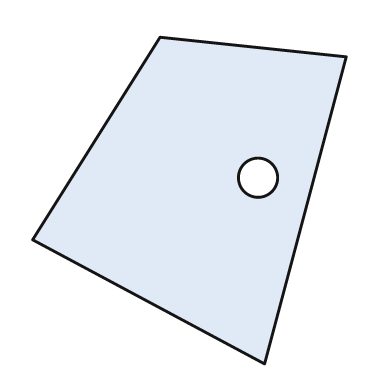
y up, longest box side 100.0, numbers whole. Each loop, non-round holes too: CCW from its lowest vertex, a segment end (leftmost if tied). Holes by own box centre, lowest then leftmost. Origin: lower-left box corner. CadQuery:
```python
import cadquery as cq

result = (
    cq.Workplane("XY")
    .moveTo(71.0, 0.0)
    .lineTo(96.0, 94.0)
    .lineTo(39.0, 100.0)
    .lineTo(0.0, 38.0)
    .close()
    .moveTo(69.0, 57.0)
    .circle(6.0)
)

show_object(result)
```